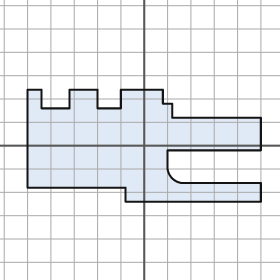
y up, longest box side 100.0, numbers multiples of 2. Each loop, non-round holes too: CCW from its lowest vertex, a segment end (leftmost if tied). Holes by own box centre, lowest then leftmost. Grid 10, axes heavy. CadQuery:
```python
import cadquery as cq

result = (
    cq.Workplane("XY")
    .moveTo(-8.0, -24.0)
    .lineTo(50.0, -24.0)
    .lineTo(50.0, -16.0)
    .lineTo(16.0, -16.0)
    .threePointArc((12.0, -14.0), (10.0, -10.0))
    .lineTo(10.0, -2.0)
    .lineTo(50.0, -2.0)
    .lineTo(50.0, 12.0)
    .lineTo(12.0, 12.0)
    .lineTo(12.0, 18.0)
    .lineTo(8.0, 18.0)
    .lineTo(8.0, 24.0)
    .lineTo(-10.0, 24.0)
    .lineTo(-10.0, 16.0)
    .lineTo(-20.0, 16.0)
    .lineTo(-20.0, 24.0)
    .lineTo(-32.0, 24.0)
    .lineTo(-32.0, 16.0)
    .lineTo(-44.0, 16.0)
    .lineTo(-44.0, 24.0)
    .lineTo(-50.0, 24.0)
    .lineTo(-50.0, -18.0)
    .lineTo(-8.0, -18.0)
    .close()
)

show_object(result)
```